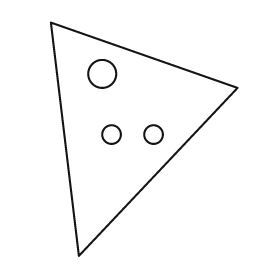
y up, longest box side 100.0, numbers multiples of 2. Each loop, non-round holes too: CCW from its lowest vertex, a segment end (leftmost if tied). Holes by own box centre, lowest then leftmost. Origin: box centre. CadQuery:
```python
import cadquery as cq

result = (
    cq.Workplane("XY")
    .moveTo(-28.0, -50.0)
    .lineTo(40.0, 22.0)
    .lineTo(-40.0, 50.0)
    .close()
    .moveTo(-14.0, 2.0)
    .circle(4.0)
    .moveTo(4.0, 2.0)
    .circle(4.0)
    .moveTo(-18.0, 28.0)
    .circle(6.0)
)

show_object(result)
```